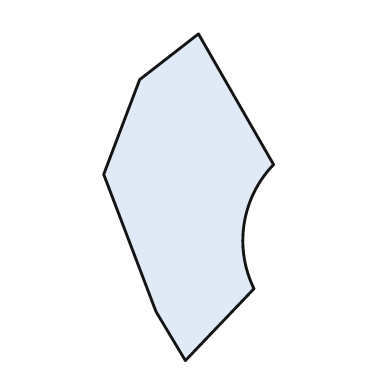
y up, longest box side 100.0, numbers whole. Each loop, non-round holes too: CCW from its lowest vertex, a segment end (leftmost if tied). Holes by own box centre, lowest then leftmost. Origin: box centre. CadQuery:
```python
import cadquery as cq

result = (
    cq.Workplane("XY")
    .moveTo(-1.0, -50.0)
    .lineTo(20.0, -28.0)
    .threePointArc((17.0, -8.0), (26.0, 10.0))
    .lineTo(3.0, 50.0)
    .lineTo(-15.0, 36.0)
    .lineTo(-26.0, 7.0)
    .lineTo(-10.0, -35.0)
    .close()
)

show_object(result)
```